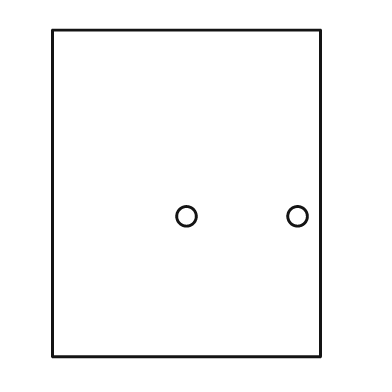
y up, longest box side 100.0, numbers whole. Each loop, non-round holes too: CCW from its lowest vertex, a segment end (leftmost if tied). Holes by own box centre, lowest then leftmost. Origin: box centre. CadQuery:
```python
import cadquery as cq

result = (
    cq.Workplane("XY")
    .moveTo(-41.0, -50.0)
    .lineTo(41.0, -50.0)
    .lineTo(41.0, 50.0)
    .lineTo(-41.0, 50.0)
    .close()
    .moveTo(0.0, -7.0)
    .circle(3.0)
    .moveTo(34.0, -7.0)
    .circle(3.0)
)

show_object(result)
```